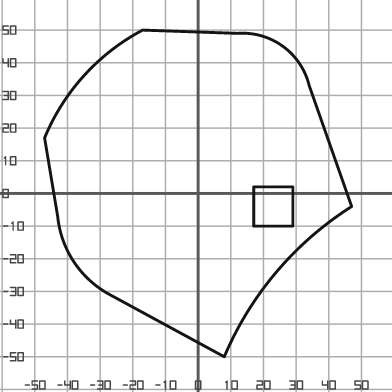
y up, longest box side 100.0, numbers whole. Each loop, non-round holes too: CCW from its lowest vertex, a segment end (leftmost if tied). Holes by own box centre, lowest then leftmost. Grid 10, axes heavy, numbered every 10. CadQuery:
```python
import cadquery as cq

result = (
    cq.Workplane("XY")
    .moveTo(8.0, -50.0)
    .threePointArc((24.0, -24.0), (47.0, -4.0))
    .lineTo(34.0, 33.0)
    .threePointArc((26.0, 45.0), (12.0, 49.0))
    .lineTo(-17.0, 50.0)
    .threePointArc((-35.0, 36.0), (-47.0, 17.0))
    .lineTo(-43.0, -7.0)
    .threePointArc((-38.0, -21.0), (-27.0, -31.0))
    .close()
    .moveTo(17.0, -10.0)
    .lineTo(29.0, -10.0)
    .lineTo(29.0, 2.0)
    .lineTo(17.0, 2.0)
    .close()
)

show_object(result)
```